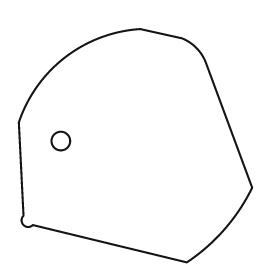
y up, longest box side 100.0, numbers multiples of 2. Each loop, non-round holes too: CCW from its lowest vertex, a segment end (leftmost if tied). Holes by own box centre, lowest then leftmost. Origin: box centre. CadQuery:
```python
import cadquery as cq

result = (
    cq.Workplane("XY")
    .moveTo(22.0, -50.0)
    .threePointArc((38.0, -36.0), (50.0, -18.0))
    .lineTo(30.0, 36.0)
    .threePointArc((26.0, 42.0), (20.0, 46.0))
    .lineTo(2.0, 50.0)
    .threePointArc((-30.0, 38.0), (-50.0, 10.0))
    .lineTo(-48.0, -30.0)
    .threePointArc((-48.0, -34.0), (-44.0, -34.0))
    .close()
    .moveTo(-32.0, 2.0)
    .circle(4.0)
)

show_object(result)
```